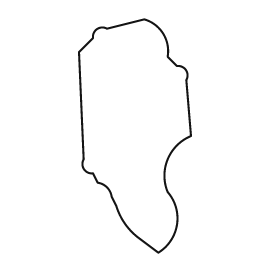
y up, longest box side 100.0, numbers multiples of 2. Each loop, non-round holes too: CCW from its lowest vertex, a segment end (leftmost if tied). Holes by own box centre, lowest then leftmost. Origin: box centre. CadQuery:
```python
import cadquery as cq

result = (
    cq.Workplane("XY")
    .moveTo(10.0, -50.0)
    .threePointArc((18.0, -38.0), (14.0, -24.0))
    .threePointArc((14.0, -10.0), (24.0, 0.0))
    .lineTo(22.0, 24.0)
    .threePointArc((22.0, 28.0), (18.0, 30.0))
    .lineTo(14.0, 34.0)
    .threePointArc((12.0, 44.0), (4.0, 50.0))
    .lineTo(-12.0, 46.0)
    .threePointArc((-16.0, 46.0), (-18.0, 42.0))
    .lineTo(-24.0, 36.0)
    .lineTo(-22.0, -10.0)
    .threePointArc((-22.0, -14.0), (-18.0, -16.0))
    .lineTo(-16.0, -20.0)
    .threePointArc((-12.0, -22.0), (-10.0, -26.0))
    .lineTo(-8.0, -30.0)
    .threePointArc((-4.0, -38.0), (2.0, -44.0))
    .close()
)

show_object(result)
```